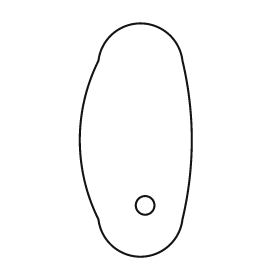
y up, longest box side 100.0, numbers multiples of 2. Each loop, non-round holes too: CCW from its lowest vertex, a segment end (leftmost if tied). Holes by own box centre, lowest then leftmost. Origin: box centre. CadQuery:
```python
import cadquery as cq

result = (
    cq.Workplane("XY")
    .moveTo(-16.0, -34.0)
    .threePointArc((2.0, -50.0), (20.0, -34.0))
    .threePointArc((24.0, 0.0), (20.0, 34.0))
    .threePointArc((2.0, 50.0), (-16.0, 34.0))
    .threePointArc((-24.0, 0.0), (-16.0, -34.0))
    .close()
    .moveTo(4.0, -28.0)
    .circle(4.0)
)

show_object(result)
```